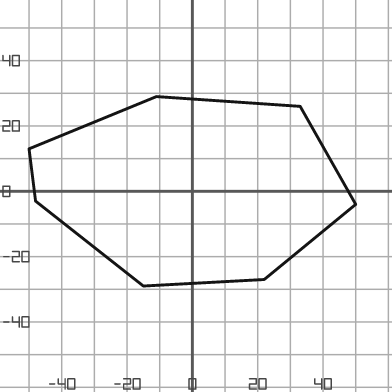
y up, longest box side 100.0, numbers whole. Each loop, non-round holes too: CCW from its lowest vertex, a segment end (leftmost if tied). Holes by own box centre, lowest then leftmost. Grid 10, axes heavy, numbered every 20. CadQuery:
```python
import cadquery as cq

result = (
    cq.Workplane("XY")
    .moveTo(-15.0, -29.0)
    .lineTo(22.0, -27.0)
    .lineTo(50.0, -4.0)
    .lineTo(33.0, 26.0)
    .lineTo(-11.0, 29.0)
    .lineTo(-50.0, 13.0)
    .lineTo(-48.0, -3.0)
    .close()
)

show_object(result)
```